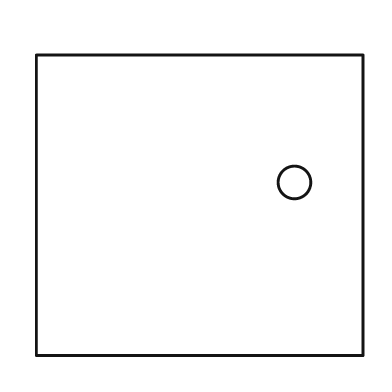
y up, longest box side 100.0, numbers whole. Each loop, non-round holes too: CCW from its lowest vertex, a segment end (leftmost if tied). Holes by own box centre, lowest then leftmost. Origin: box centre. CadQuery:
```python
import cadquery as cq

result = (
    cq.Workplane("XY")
    .moveTo(-50.0, -46.0)
    .lineTo(50.0, -46.0)
    .lineTo(50.0, 46.0)
    .lineTo(-50.0, 46.0)
    .close()
    .moveTo(29.0, 7.0)
    .circle(5.0)
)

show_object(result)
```